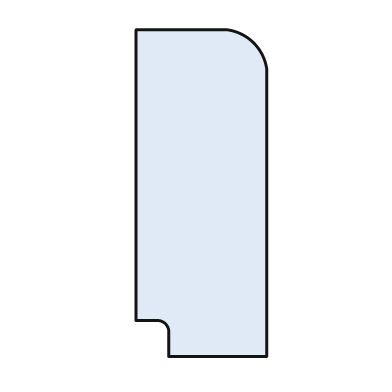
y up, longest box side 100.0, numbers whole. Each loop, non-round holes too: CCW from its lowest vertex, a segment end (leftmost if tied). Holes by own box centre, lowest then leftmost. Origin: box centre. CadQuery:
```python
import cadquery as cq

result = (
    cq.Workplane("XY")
    .moveTo(-10.0, -50.0)
    .lineTo(20.0, -50.0)
    .lineTo(20.0, 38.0)
    .threePointArc((16.0, 46.0), (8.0, 50.0))
    .lineTo(-20.0, 50.0)
    .lineTo(-20.0, -39.0)
    .lineTo(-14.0, -39.0)
    .threePointArc((-11.0, -40.0), (-10.0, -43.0))
    .close()
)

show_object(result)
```